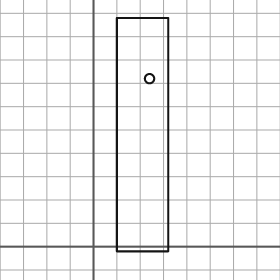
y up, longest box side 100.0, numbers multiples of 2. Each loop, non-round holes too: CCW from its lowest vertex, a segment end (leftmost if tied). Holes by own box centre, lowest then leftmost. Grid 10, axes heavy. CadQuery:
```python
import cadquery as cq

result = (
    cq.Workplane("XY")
    .moveTo(10.0, -2.0)
    .lineTo(32.0, -2.0)
    .lineTo(32.0, 98.0)
    .lineTo(10.0, 98.0)
    .close()
    .moveTo(24.0, 72.0)
    .circle(2.0)
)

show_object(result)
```